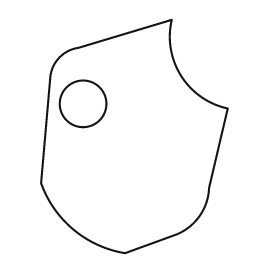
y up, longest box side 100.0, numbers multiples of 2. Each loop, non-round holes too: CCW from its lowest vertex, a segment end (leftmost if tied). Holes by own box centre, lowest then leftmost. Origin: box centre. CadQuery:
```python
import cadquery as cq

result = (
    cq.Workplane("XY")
    .moveTo(-4.0, -50.0)
    .lineTo(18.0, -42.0)
    .threePointArc((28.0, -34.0), (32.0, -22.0))
    .lineTo(40.0, 12.0)
    .threePointArc((20.0, 26.0), (16.0, 50.0))
    .lineTo(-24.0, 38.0)
    .threePointArc((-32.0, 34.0), (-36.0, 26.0))
    .lineTo(-40.0, -20.0)
    .threePointArc((-26.0, -40.0), (-4.0, -50.0))
    .close()
    .moveTo(-22.0, 14.0)
    .circle(10.0)
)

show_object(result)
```